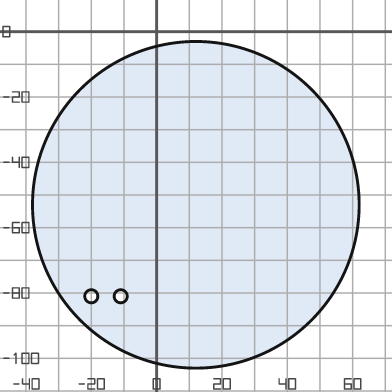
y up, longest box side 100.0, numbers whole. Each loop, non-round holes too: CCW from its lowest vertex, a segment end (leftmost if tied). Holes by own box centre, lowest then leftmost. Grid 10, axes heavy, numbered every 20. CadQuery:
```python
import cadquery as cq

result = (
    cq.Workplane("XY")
    .moveTo(12.0, -53.0)
    .circle(50.0)
    .moveTo(-20.0, -81.0)
    .circle(2.0)
    .moveTo(-11.0, -81.0)
    .circle(2.0)
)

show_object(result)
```